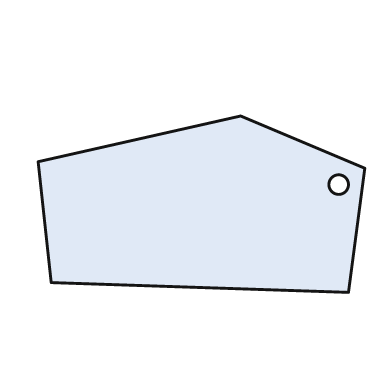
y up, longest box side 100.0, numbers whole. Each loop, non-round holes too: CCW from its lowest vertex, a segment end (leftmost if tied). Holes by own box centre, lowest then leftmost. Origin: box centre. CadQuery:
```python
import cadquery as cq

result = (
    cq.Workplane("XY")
    .moveTo(45.0, -27.0)
    .lineTo(50.0, 11.0)
    .lineTo(12.0, 27.0)
    .lineTo(-50.0, 13.0)
    .lineTo(-46.0, -24.0)
    .close()
    .moveTo(42.0, 6.0)
    .circle(3.0)
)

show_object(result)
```